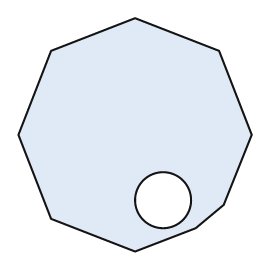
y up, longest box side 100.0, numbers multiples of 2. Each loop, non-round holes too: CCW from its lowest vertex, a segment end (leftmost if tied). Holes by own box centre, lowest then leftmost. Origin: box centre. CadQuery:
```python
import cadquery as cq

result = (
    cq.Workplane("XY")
    .moveTo(0.0, -50.0)
    .lineTo(26.0, -40.0)
    .lineTo(38.0, -30.0)
    .lineTo(50.0, 0.0)
    .lineTo(36.0, 36.0)
    .lineTo(0.0, 50.0)
    .lineTo(-36.0, 36.0)
    .lineTo(-50.0, 0.0)
    .lineTo(-36.0, -36.0)
    .close()
    .moveTo(12.0, -28.0)
    .circle(12.0)
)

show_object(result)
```